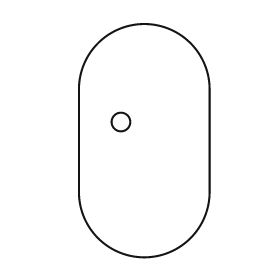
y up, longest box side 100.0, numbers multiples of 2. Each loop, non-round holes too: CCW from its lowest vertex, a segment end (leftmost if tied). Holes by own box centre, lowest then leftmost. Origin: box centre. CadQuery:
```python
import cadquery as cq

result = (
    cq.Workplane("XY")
    .moveTo(-28.0, -22.0)
    .threePointArc((0.0, -50.0), (28.0, -22.0))
    .lineTo(28.0, 22.0)
    .threePointArc((0.0, 50.0), (-28.0, 22.0))
    .close()
    .moveTo(-10.0, 8.0)
    .circle(4.0)
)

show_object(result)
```